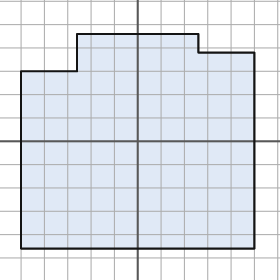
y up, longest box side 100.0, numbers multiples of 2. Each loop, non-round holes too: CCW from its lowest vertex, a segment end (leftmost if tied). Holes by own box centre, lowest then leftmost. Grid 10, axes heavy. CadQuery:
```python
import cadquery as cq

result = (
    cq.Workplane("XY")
    .moveTo(-50.0, -46.0)
    .lineTo(50.0, -46.0)
    .lineTo(50.0, 38.0)
    .lineTo(26.0, 38.0)
    .lineTo(26.0, 46.0)
    .lineTo(-26.0, 46.0)
    .lineTo(-26.0, 30.0)
    .lineTo(-50.0, 30.0)
    .close()
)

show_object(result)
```